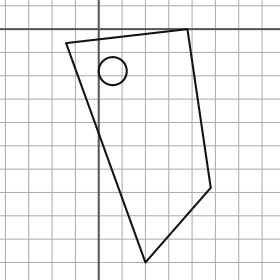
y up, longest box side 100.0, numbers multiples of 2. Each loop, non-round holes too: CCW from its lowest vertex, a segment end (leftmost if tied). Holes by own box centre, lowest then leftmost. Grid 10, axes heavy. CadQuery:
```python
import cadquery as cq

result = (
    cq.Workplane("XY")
    .moveTo(20.0, -100.0)
    .lineTo(48.0, -68.0)
    .lineTo(38.0, 0.0)
    .lineTo(-14.0, -6.0)
    .close()
    .moveTo(6.0, -18.0)
    .circle(6.0)
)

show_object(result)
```